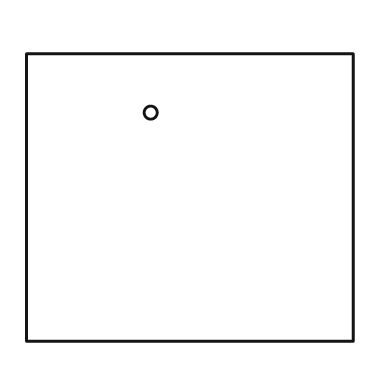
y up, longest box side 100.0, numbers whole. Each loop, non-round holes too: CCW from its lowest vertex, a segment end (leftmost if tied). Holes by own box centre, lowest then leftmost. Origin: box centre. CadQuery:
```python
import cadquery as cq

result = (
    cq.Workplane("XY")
    .moveTo(-50.0, -44.0)
    .lineTo(50.0, -44.0)
    .lineTo(50.0, 44.0)
    .lineTo(-50.0, 44.0)
    .close()
    .moveTo(-12.0, 26.0)
    .circle(2.0)
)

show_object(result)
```